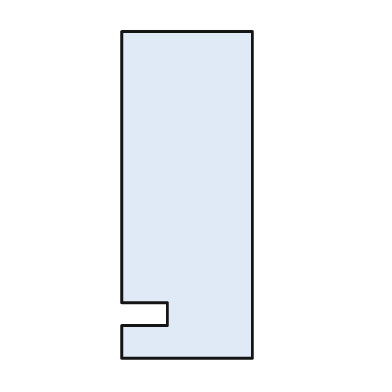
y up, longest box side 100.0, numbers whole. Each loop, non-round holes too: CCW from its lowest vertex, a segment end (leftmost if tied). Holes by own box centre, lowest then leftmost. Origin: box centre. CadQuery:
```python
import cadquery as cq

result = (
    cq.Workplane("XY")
    .moveTo(-20.0, -50.0)
    .lineTo(20.0, -50.0)
    .lineTo(20.0, 50.0)
    .lineTo(-20.0, 50.0)
    .lineTo(-20.0, -33.0)
    .lineTo(-6.0, -33.0)
    .lineTo(-6.0, -40.0)
    .lineTo(-20.0, -40.0)
    .close()
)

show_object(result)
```